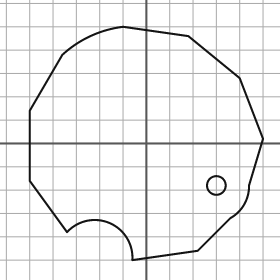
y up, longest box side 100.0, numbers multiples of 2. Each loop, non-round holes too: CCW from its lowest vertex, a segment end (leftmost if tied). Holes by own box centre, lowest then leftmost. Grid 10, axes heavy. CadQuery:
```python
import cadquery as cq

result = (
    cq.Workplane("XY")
    .moveTo(-6.0, -50.0)
    .lineTo(22.0, -46.0)
    .lineTo(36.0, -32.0)
    .threePointArc((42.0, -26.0), (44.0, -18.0))
    .lineTo(50.0, 2.0)
    .lineTo(40.0, 28.0)
    .lineTo(18.0, 46.0)
    .lineTo(-10.0, 50.0)
    .threePointArc((-24.0, 46.0), (-36.0, 38.0))
    .lineTo(-50.0, 14.0)
    .lineTo(-50.0, -16.0)
    .lineTo(-34.0, -38.0)
    .threePointArc((-16.0, -34.0), (-6.0, -50.0))
    .close()
    .moveTo(30.0, -18.0)
    .circle(4.0)
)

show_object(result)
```